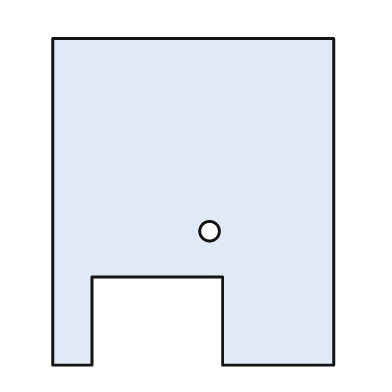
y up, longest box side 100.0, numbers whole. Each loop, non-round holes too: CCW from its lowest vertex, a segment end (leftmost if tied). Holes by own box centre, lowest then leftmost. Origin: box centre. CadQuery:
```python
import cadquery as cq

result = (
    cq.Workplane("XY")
    .moveTo(-43.0, -50.0)
    .lineTo(-31.0, -50.0)
    .lineTo(-31.0, -23.0)
    .lineTo(9.0, -23.0)
    .lineTo(9.0, -50.0)
    .lineTo(43.0, -50.0)
    .lineTo(43.0, 50.0)
    .lineTo(-43.0, 50.0)
    .close()
    .moveTo(5.0, -9.0)
    .circle(3.0)
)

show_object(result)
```